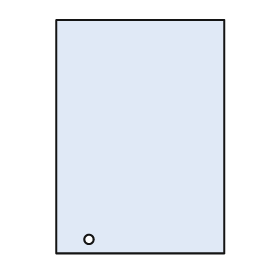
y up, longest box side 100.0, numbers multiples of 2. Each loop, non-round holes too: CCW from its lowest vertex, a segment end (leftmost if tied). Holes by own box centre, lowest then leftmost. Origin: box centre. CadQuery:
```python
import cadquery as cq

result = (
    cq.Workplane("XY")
    .moveTo(-36.0, -50.0)
    .lineTo(36.0, -50.0)
    .lineTo(36.0, 50.0)
    .lineTo(-36.0, 50.0)
    .close()
    .moveTo(-22.0, -44.0)
    .circle(2.0)
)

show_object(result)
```